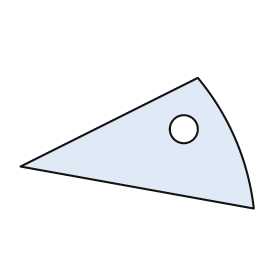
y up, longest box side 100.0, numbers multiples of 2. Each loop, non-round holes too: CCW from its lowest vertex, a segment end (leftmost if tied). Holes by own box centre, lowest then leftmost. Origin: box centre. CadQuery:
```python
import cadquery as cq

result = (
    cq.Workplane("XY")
    .moveTo(50.0, -28.0)
    .threePointArc((42.0, 2.0), (26.0, 28.0))
    .lineTo(-50.0, -10.0)
    .close()
    .moveTo(20.0, 6.0)
    .circle(6.0)
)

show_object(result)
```